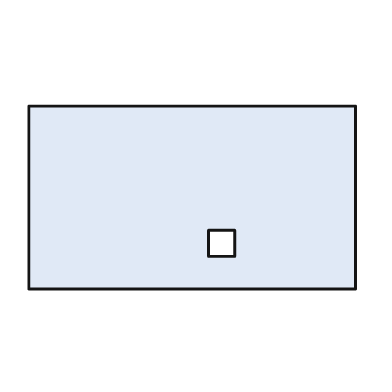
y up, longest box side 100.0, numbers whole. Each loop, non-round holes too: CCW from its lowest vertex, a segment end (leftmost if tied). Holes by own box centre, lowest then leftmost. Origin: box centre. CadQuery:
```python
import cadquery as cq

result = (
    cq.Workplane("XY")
    .moveTo(-50.0, -28.0)
    .lineTo(50.0, -28.0)
    .lineTo(50.0, 28.0)
    .lineTo(-50.0, 28.0)
    .close()
    .moveTo(5.0, -18.0)
    .lineTo(13.0, -18.0)
    .lineTo(13.0, -10.0)
    .lineTo(5.0, -10.0)
    .close()
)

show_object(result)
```